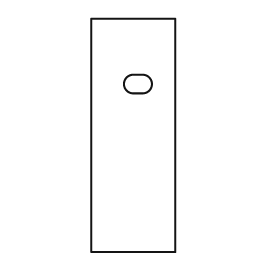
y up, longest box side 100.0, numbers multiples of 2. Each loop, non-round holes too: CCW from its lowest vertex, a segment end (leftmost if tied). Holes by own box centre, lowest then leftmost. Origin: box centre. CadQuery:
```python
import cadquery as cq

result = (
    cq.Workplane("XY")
    .moveTo(-18.0, -50.0)
    .lineTo(18.0, -50.0)
    .lineTo(18.0, 50.0)
    .lineTo(-18.0, 50.0)
    .close()
    .moveTo(0.0, 18.0)
    .lineTo(4.0, 18.0)
    .threePointArc((8.0, 22.0), (4.0, 26.0))
    .lineTo(0.0, 26.0)
    .threePointArc((-4.0, 22.0), (0.0, 18.0))
    .close()
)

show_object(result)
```